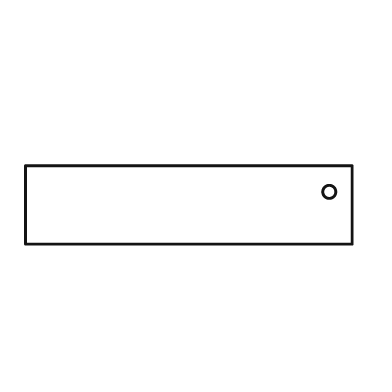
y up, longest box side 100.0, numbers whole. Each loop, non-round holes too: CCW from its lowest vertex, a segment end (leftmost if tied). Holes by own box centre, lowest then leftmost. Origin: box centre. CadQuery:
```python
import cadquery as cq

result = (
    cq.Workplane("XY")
    .moveTo(-50.0, -12.0)
    .lineTo(50.0, -12.0)
    .lineTo(50.0, 12.0)
    .lineTo(-50.0, 12.0)
    .close()
    .moveTo(43.0, 4.0)
    .circle(2.0)
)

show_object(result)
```